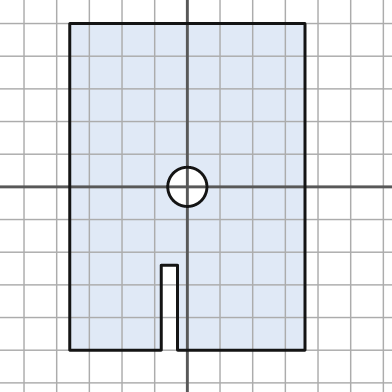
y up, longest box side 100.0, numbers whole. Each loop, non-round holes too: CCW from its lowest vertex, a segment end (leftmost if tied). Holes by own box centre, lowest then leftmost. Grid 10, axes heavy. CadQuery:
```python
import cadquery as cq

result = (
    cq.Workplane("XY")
    .moveTo(-36.0, -50.0)
    .lineTo(-8.0, -50.0)
    .lineTo(-8.0, -24.0)
    .lineTo(-3.0, -24.0)
    .lineTo(-3.0, -50.0)
    .lineTo(36.0, -50.0)
    .lineTo(36.0, 50.0)
    .lineTo(-36.0, 50.0)
    .close()
    .moveTo(0.0, 0.0)
    .circle(6.0)
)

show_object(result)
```